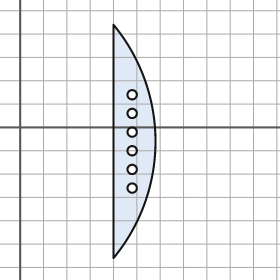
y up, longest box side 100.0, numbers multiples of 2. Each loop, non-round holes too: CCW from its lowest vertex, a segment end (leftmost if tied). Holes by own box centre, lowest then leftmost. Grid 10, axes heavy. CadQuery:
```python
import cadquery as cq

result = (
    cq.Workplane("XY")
    .moveTo(40.0, -56.0)
    .threePointArc((58.0, -6.0), (40.0, 44.0))
    .close()
    .moveTo(48.0, -26.0)
    .circle(2.0)
    .moveTo(48.0, -18.0)
    .circle(2.0)
    .moveTo(48.0, -10.0)
    .circle(2.0)
    .moveTo(48.0, -2.0)
    .circle(2.0)
    .moveTo(48.0, 6.0)
    .circle(2.0)
    .moveTo(48.0, 14.0)
    .circle(2.0)
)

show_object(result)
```